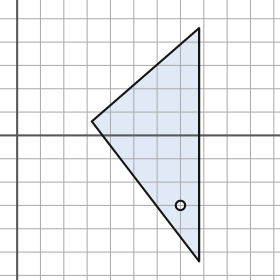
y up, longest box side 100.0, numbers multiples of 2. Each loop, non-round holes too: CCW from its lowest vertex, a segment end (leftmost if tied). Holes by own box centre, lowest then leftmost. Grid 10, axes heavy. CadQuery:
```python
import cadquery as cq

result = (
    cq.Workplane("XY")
    .moveTo(78.0, -54.0)
    .lineTo(78.0, 46.0)
    .lineTo(32.0, 6.0)
    .close()
    .moveTo(70.0, -30.0)
    .circle(2.0)
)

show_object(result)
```